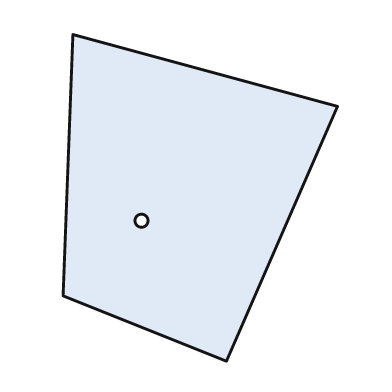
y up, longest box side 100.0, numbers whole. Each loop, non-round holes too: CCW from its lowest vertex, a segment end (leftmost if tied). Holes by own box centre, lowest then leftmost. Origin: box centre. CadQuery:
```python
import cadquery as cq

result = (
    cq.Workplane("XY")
    .moveTo(8.0, -50.0)
    .lineTo(42.0, 28.0)
    .lineTo(-39.0, 50.0)
    .lineTo(-42.0, -30.0)
    .close()
    .moveTo(-18.0, -7.0)
    .circle(2.0)
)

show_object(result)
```